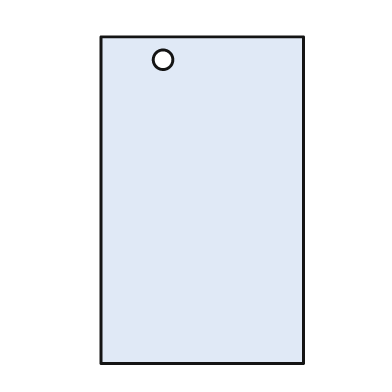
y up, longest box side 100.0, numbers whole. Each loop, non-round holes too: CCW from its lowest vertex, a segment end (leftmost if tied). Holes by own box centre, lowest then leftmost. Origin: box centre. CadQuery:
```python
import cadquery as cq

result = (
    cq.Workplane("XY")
    .moveTo(-31.0, -50.0)
    .lineTo(31.0, -50.0)
    .lineTo(31.0, 50.0)
    .lineTo(-31.0, 50.0)
    .close()
    .moveTo(-12.0, 43.0)
    .circle(3.0)
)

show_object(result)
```